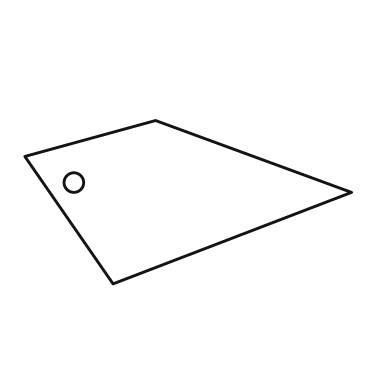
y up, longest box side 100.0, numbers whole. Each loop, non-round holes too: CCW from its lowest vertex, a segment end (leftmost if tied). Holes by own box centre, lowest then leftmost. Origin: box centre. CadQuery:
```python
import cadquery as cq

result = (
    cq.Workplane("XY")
    .moveTo(-23.0, -25.0)
    .lineTo(50.0, 3.0)
    .lineTo(-10.0, 25.0)
    .lineTo(-50.0, 14.0)
    .close()
    .moveTo(-35.0, 6.0)
    .circle(3.0)
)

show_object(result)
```